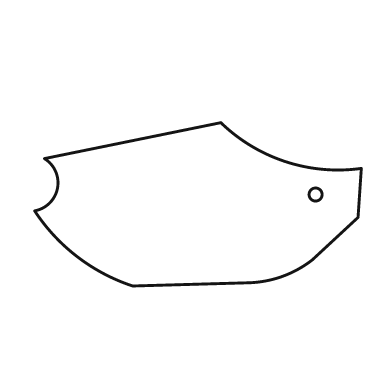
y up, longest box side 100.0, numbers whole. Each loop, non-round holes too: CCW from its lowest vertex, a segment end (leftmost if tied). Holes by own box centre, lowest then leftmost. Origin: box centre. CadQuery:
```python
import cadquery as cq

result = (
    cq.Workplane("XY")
    .moveTo(-20.0, -25.0)
    .lineTo(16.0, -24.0)
    .threePointArc((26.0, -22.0), (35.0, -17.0))
    .lineTo(49.0, -4.0)
    .lineTo(50.0, 11.0)
    .threePointArc((27.0, 13.0), (7.0, 25.0))
    .lineTo(-47.0, 14.0)
    .threePointArc((-43.0, 5.0), (-50.0, -2.0))
    .threePointArc((-37.0, -16.0), (-20.0, -25.0))
    .close()
    .moveTo(36.0, 3.0)
    .circle(2.0)
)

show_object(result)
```